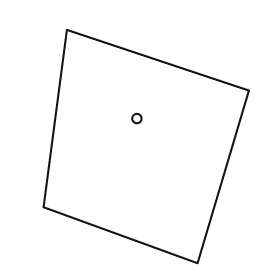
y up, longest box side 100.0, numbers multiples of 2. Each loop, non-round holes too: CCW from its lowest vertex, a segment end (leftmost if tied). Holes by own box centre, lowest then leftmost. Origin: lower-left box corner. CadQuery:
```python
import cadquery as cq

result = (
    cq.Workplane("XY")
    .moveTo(66.0, 0.0)
    .lineTo(88.0, 74.0)
    .lineTo(10.0, 100.0)
    .lineTo(0.0, 24.0)
    .close()
    .moveTo(40.0, 62.0)
    .circle(2.0)
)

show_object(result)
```